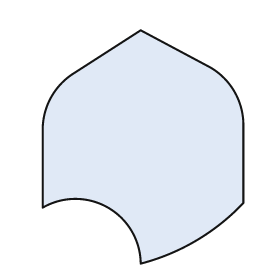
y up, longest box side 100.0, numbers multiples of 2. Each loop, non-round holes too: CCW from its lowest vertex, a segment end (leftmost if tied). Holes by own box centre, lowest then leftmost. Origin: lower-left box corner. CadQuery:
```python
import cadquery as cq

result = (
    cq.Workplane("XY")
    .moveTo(42.0, 0.0)
    .threePointArc((66.0, 10.0), (86.0, 26.0))
    .lineTo(86.0, 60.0)
    .threePointArc((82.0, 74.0), (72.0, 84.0))
    .lineTo(42.0, 100.0)
    .lineTo(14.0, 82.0)
    .threePointArc((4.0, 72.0), (0.0, 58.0))
    .lineTo(0.0, 24.0)
    .threePointArc((28.0, 24.0), (42.0, 0.0))
    .close()
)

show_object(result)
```